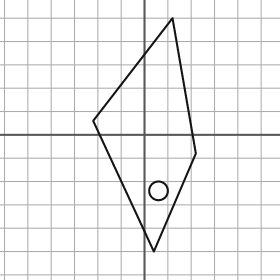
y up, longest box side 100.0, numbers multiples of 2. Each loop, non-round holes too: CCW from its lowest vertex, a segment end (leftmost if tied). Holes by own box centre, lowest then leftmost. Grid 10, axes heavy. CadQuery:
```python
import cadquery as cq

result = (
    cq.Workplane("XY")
    .moveTo(4.0, -50.0)
    .lineTo(22.0, -8.0)
    .lineTo(12.0, 50.0)
    .lineTo(-22.0, 6.0)
    .close()
    .moveTo(6.0, -24.0)
    .circle(4.0)
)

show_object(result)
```